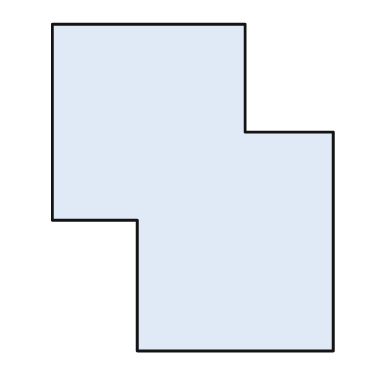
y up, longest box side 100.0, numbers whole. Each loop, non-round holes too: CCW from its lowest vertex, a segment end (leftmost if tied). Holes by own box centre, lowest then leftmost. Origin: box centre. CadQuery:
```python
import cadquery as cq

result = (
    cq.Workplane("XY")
    .moveTo(-17.0, -50.0)
    .lineTo(43.0, -50.0)
    .lineTo(43.0, 17.0)
    .lineTo(16.0, 17.0)
    .lineTo(16.0, 50.0)
    .lineTo(-43.0, 50.0)
    .lineTo(-43.0, -10.0)
    .lineTo(-17.0, -10.0)
    .close()
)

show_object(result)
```